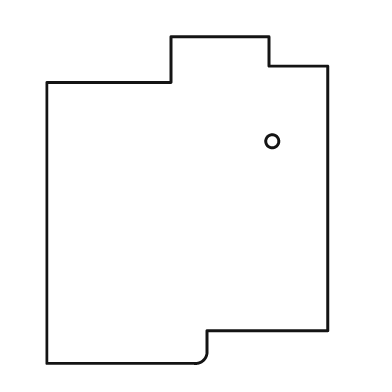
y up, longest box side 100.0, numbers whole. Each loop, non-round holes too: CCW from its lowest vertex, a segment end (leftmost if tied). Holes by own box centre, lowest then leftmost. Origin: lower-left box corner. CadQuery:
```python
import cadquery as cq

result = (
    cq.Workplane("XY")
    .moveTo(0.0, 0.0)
    .lineTo(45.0, 0.0)
    .threePointArc((48.0, 1.0), (49.0, 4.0))
    .lineTo(49.0, 10.0)
    .lineTo(86.0, 10.0)
    .lineTo(86.0, 91.0)
    .lineTo(68.0, 91.0)
    .lineTo(68.0, 100.0)
    .lineTo(38.0, 100.0)
    .lineTo(38.0, 86.0)
    .lineTo(0.0, 86.0)
    .close()
    .moveTo(69.0, 68.0)
    .circle(2.0)
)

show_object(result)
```